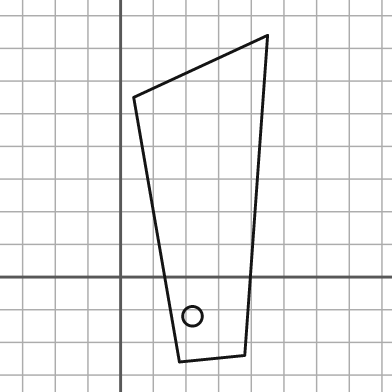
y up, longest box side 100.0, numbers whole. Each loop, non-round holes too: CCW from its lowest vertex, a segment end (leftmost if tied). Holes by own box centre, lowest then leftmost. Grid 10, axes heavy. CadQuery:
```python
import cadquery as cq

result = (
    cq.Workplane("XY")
    .moveTo(18.0, -26.0)
    .lineTo(38.0, -24.0)
    .lineTo(45.0, 74.0)
    .lineTo(4.0, 55.0)
    .close()
    .moveTo(22.0, -12.0)
    .circle(3.0)
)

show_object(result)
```